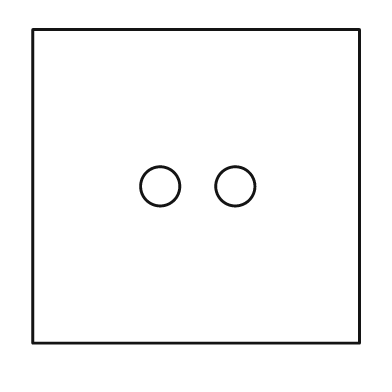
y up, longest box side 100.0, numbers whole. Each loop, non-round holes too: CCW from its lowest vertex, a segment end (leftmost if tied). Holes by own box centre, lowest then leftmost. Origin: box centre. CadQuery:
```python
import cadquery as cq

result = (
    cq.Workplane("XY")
    .moveTo(-50.0, -48.0)
    .lineTo(50.0, -48.0)
    .lineTo(50.0, 48.0)
    .lineTo(-50.0, 48.0)
    .close()
    .moveTo(-11.0, 0.0)
    .circle(6.0)
    .moveTo(12.0, 0.0)
    .circle(6.0)
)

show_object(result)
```